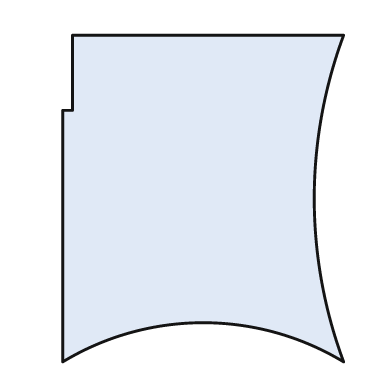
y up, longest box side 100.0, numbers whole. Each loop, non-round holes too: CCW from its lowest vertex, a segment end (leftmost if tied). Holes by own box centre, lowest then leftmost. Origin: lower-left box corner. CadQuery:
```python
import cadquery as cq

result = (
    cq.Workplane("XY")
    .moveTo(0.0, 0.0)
    .threePointArc((43.0, 12.0), (86.0, 0.0))
    .threePointArc((77.0, 50.0), (86.0, 100.0))
    .lineTo(3.0, 100.0)
    .lineTo(3.0, 77.0)
    .lineTo(0.0, 77.0)
    .close()
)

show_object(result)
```